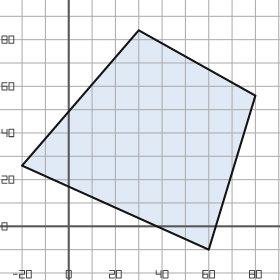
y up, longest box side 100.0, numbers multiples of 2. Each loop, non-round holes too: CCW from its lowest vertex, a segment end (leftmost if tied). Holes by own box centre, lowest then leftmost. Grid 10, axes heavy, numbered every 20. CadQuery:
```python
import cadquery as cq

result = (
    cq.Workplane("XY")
    .moveTo(60.0, -10.0)
    .lineTo(80.0, 56.0)
    .lineTo(30.0, 84.0)
    .lineTo(-20.0, 26.0)
    .close()
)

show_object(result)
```